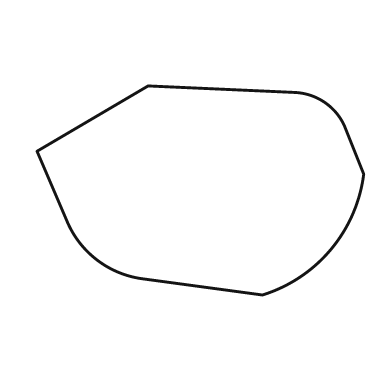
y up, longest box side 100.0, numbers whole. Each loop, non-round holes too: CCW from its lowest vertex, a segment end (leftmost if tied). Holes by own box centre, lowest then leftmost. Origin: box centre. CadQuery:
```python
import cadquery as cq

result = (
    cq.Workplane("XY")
    .moveTo(19.0, -32.0)
    .threePointArc((40.0, -18.0), (50.0, 5.0))
    .lineTo(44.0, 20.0)
    .threePointArc((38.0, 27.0), (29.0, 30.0))
    .lineTo(-16.0, 32.0)
    .lineTo(-50.0, 12.0)
    .lineTo(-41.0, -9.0)
    .threePointArc((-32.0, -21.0), (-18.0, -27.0))
    .close()
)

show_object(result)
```